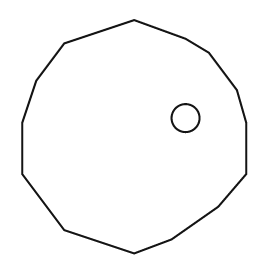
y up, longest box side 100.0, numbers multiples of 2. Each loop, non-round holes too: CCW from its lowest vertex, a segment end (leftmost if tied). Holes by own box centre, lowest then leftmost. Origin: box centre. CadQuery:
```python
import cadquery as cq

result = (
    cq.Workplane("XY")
    .moveTo(0.0, -50.0)
    .lineTo(16.0, -44.0)
    .lineTo(36.0, -30.0)
    .lineTo(48.0, -16.0)
    .lineTo(48.0, 6.0)
    .lineTo(44.0, 20.0)
    .lineTo(32.0, 36.0)
    .lineTo(22.0, 42.0)
    .lineTo(0.0, 50.0)
    .lineTo(-30.0, 40.0)
    .lineTo(-42.0, 24.0)
    .lineTo(-48.0, 6.0)
    .lineTo(-48.0, -16.0)
    .lineTo(-30.0, -40.0)
    .close()
    .moveTo(22.0, 8.0)
    .circle(6.0)
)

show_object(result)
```